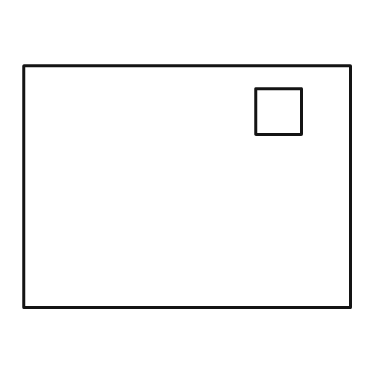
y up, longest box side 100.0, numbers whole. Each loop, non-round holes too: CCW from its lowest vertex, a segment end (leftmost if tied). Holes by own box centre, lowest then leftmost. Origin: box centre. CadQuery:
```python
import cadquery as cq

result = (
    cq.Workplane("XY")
    .moveTo(-50.0, -37.0)
    .lineTo(50.0, -37.0)
    .lineTo(50.0, 37.0)
    .lineTo(-50.0, 37.0)
    .close()
    .moveTo(21.0, 16.0)
    .lineTo(35.0, 16.0)
    .lineTo(35.0, 30.0)
    .lineTo(21.0, 30.0)
    .close()
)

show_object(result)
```